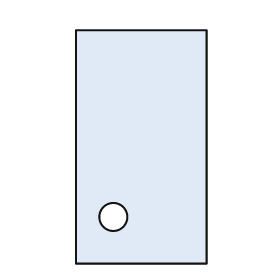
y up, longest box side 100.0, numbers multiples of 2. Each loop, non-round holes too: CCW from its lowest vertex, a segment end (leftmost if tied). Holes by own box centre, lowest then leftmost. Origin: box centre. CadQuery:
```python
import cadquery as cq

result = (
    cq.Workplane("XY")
    .moveTo(-28.0, -50.0)
    .lineTo(28.0, -50.0)
    .lineTo(28.0, 50.0)
    .lineTo(-28.0, 50.0)
    .close()
    .moveTo(-12.0, -30.0)
    .circle(6.0)
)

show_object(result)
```